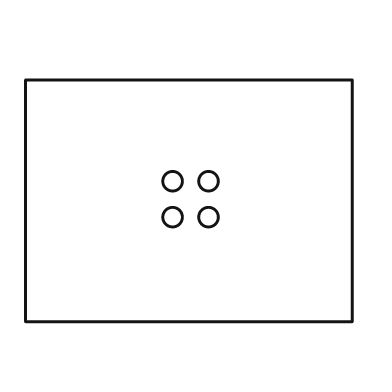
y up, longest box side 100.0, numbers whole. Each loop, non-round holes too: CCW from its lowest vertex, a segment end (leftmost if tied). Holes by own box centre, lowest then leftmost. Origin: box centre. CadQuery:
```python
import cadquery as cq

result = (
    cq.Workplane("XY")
    .moveTo(-50.0, -37.0)
    .lineTo(50.0, -37.0)
    .lineTo(50.0, 37.0)
    .lineTo(-50.0, 37.0)
    .close()
    .moveTo(-5.0, -5.0)
    .circle(3.0)
    .moveTo(6.0, -5.0)
    .circle(3.0)
    .moveTo(-5.0, 6.0)
    .circle(3.0)
    .moveTo(6.0, 6.0)
    .circle(3.0)
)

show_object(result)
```